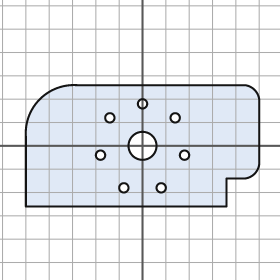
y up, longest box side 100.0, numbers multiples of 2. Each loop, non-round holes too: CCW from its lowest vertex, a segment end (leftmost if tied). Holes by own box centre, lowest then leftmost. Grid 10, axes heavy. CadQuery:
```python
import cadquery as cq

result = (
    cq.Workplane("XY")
    .moveTo(-50.0, -26.0)
    .lineTo(36.0, -26.0)
    .lineTo(36.0, -14.0)
    .lineTo(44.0, -14.0)
    .threePointArc((48.0, -12.0), (50.0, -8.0))
    .lineTo(50.0, 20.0)
    .threePointArc((48.0, 24.0), (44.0, 26.0))
    .lineTo(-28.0, 26.0)
    .threePointArc((-44.0, 20.0), (-50.0, 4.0))
    .close()
    .moveTo(-8.0, -18.0)
    .circle(2.0)
    .moveTo(8.0, -18.0)
    .circle(2.0)
    .moveTo(-18.0, -4.0)
    .circle(2.0)
    .moveTo(18.0, -4.0)
    .circle(2.0)
    .moveTo(0.0, 0.0)
    .circle(6.0)
    .moveTo(-14.0, 12.0)
    .circle(2.0)
    .moveTo(14.0, 12.0)
    .circle(2.0)
    .moveTo(0.0, 18.0)
    .circle(2.0)
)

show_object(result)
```